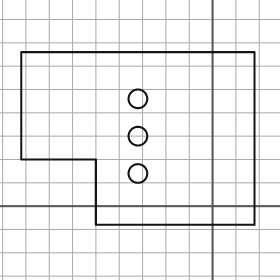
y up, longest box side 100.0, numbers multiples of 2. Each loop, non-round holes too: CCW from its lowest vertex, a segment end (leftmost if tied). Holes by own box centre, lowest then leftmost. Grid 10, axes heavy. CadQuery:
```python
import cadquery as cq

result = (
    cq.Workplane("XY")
    .moveTo(-50.0, -8.0)
    .lineTo(18.0, -8.0)
    .lineTo(18.0, 66.0)
    .lineTo(-82.0, 66.0)
    .lineTo(-82.0, 20.0)
    .lineTo(-50.0, 20.0)
    .close()
    .moveTo(-32.0, 14.0)
    .circle(4.0)
    .moveTo(-32.0, 30.0)
    .circle(4.0)
    .moveTo(-32.0, 46.0)
    .circle(4.0)
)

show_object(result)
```